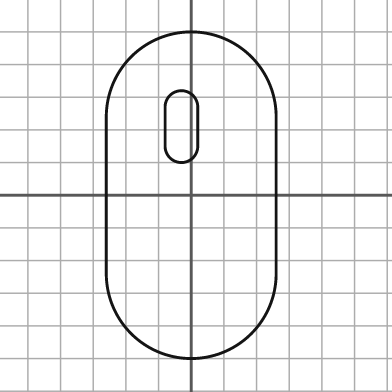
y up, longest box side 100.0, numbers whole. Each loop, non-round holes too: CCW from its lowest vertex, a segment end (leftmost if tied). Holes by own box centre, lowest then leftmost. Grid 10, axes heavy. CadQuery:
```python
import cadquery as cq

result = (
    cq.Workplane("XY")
    .moveTo(-26.0, -24.0)
    .threePointArc((0.0, -50.0), (26.0, -24.0))
    .lineTo(26.0, 24.0)
    .threePointArc((0.0, 50.0), (-26.0, 24.0))
    .close()
    .moveTo(-8.0, 15.0)
    .threePointArc((-3.0, 10.0), (2.0, 15.0))
    .lineTo(2.0, 27.0)
    .threePointArc((-3.0, 32.0), (-8.0, 27.0))
    .close()
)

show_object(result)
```